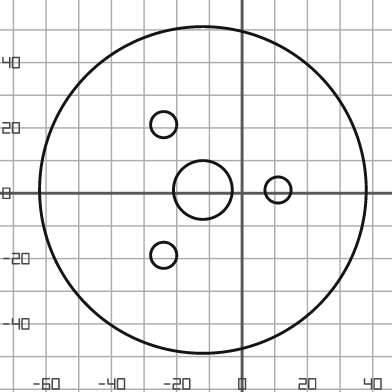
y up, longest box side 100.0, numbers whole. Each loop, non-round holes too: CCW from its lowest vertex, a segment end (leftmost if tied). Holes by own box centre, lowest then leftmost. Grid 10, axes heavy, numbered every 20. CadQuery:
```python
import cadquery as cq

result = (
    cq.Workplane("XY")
    .moveTo(-12.0, 1.0)
    .circle(50.0)
    .moveTo(-24.0, -19.0)
    .circle(4.0)
    .moveTo(-12.0, 1.0)
    .circle(9.0)
    .moveTo(11.0, 1.0)
    .circle(4.0)
    .moveTo(-24.0, 21.0)
    .circle(4.0)
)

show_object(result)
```